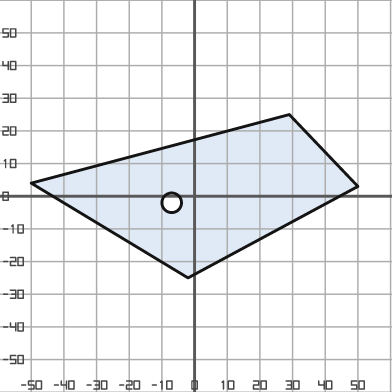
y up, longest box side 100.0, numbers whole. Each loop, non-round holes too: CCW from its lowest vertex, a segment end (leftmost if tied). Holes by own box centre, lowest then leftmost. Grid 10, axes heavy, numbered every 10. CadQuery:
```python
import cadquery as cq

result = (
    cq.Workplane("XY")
    .moveTo(-2.0, -25.0)
    .lineTo(50.0, 3.0)
    .lineTo(29.0, 25.0)
    .lineTo(-50.0, 4.0)
    .close()
    .moveTo(-7.0, -2.0)
    .circle(3.0)
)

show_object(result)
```